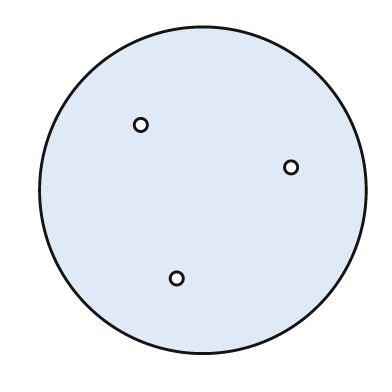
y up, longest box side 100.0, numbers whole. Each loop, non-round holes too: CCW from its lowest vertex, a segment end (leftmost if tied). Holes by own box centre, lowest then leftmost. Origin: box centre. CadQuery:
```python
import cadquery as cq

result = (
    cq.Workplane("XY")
    .moveTo(0.0, 0.0)
    .circle(50.0)
    .moveTo(-8.0, -27.0)
    .circle(2.0)
    .moveTo(27.0, 7.0)
    .circle(2.0)
    .moveTo(-19.0, 20.0)
    .circle(2.0)
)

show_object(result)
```